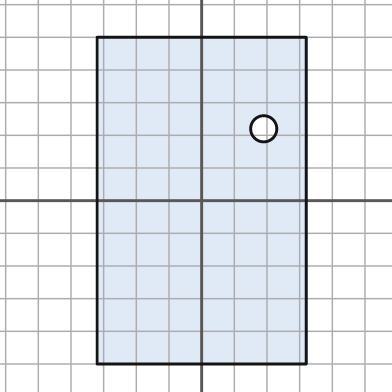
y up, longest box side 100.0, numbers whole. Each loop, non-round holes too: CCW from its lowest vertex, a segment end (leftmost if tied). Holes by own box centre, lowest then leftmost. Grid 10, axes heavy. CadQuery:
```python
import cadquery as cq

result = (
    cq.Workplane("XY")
    .moveTo(-32.0, -50.0)
    .lineTo(32.0, -50.0)
    .lineTo(32.0, 50.0)
    .lineTo(-32.0, 50.0)
    .close()
    .moveTo(19.0, 22.0)
    .circle(4.0)
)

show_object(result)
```